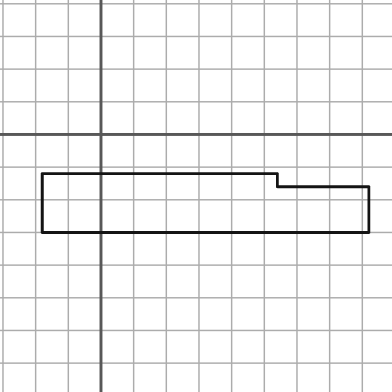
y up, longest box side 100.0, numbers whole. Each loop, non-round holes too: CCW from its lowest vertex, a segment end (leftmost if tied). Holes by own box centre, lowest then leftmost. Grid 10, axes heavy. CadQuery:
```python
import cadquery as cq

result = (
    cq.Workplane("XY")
    .moveTo(-18.0, -30.0)
    .lineTo(82.0, -30.0)
    .lineTo(82.0, -16.0)
    .lineTo(54.0, -16.0)
    .lineTo(54.0, -12.0)
    .lineTo(-18.0, -12.0)
    .close()
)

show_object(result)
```